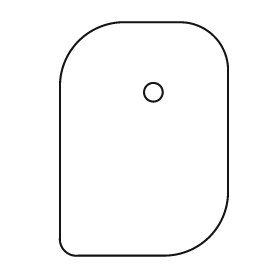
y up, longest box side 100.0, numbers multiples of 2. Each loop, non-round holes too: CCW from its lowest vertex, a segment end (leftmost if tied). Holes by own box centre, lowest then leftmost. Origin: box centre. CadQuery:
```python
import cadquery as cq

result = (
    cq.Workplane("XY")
    .moveTo(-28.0, -50.0)
    .lineTo(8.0, -50.0)
    .threePointArc((28.0, -42.0), (36.0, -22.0))
    .lineTo(36.0, 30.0)
    .threePointArc((30.0, 44.0), (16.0, 50.0))
    .lineTo(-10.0, 50.0)
    .threePointArc((-28.0, 42.0), (-36.0, 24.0))
    .lineTo(-36.0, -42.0)
    .threePointArc((-34.0, -48.0), (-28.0, -50.0))
    .close()
    .moveTo(4.0, 20.0)
    .circle(4.0)
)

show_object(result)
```